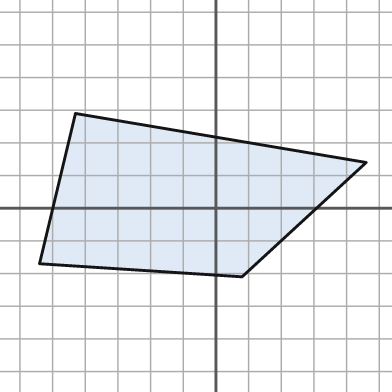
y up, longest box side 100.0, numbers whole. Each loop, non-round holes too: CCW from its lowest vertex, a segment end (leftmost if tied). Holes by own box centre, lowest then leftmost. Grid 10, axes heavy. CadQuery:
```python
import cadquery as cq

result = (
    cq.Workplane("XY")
    .moveTo(8.0, -21.0)
    .lineTo(46.0, 14.0)
    .lineTo(-43.0, 29.0)
    .lineTo(-54.0, -17.0)
    .close()
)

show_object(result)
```